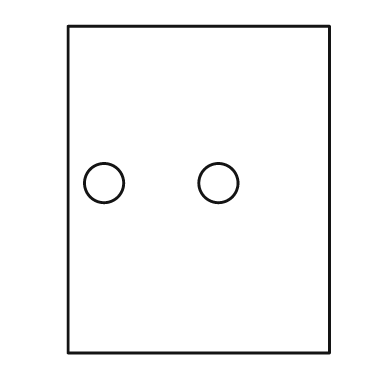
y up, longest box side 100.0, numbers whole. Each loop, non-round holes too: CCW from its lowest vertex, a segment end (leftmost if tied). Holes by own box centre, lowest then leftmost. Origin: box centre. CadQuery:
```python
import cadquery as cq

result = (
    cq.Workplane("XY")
    .moveTo(-40.0, -50.0)
    .lineTo(40.0, -50.0)
    .lineTo(40.0, 50.0)
    .lineTo(-40.0, 50.0)
    .close()
    .moveTo(-29.0, 2.0)
    .circle(6.0)
    .moveTo(6.0, 2.0)
    .circle(6.0)
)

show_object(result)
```